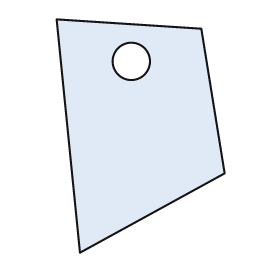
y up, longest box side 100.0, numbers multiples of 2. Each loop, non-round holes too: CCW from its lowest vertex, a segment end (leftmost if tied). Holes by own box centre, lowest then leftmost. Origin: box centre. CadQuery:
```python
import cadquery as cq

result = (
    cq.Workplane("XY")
    .moveTo(-26.0, -50.0)
    .lineTo(36.0, -16.0)
    .lineTo(26.0, 46.0)
    .lineTo(-36.0, 50.0)
    .close()
    .moveTo(-4.0, 32.0)
    .circle(8.0)
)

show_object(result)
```